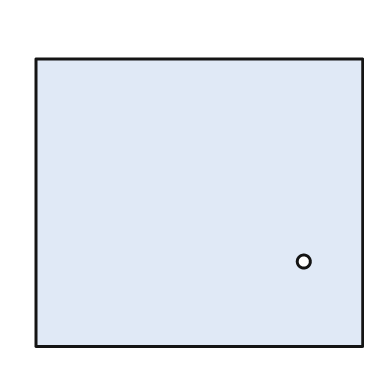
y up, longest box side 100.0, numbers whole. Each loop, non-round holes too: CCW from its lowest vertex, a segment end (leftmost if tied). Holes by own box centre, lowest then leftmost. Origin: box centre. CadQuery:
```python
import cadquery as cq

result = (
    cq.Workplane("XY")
    .moveTo(-50.0, -44.0)
    .lineTo(50.0, -44.0)
    .lineTo(50.0, 44.0)
    .lineTo(-50.0, 44.0)
    .close()
    .moveTo(32.0, -18.0)
    .circle(2.0)
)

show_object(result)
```